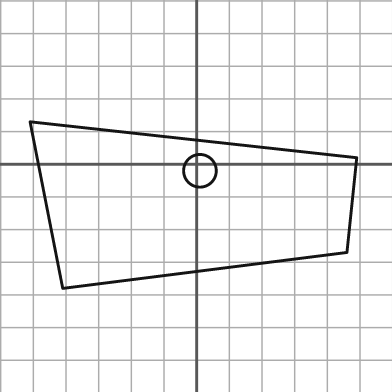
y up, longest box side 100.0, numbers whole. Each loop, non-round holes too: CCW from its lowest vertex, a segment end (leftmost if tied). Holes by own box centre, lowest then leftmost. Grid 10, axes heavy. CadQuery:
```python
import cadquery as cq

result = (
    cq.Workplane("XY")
    .moveTo(-41.0, -38.0)
    .lineTo(46.0, -27.0)
    .lineTo(49.0, 2.0)
    .lineTo(-51.0, 13.0)
    .close()
    .moveTo(1.0, -2.0)
    .circle(5.0)
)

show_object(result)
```